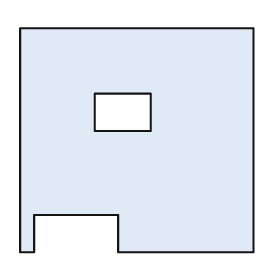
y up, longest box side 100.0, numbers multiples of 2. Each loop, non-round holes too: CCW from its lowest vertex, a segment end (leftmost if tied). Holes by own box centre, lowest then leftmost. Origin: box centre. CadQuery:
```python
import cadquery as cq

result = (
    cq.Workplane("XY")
    .moveTo(-50.0, -48.0)
    .lineTo(-44.0, -48.0)
    .lineTo(-44.0, -32.0)
    .lineTo(-8.0, -32.0)
    .lineTo(-8.0, -48.0)
    .lineTo(50.0, -48.0)
    .lineTo(50.0, 48.0)
    .lineTo(-50.0, 48.0)
    .close()
    .moveTo(-18.0, 4.0)
    .lineTo(6.0, 4.0)
    .lineTo(6.0, 20.0)
    .lineTo(-18.0, 20.0)
    .close()
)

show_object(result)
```